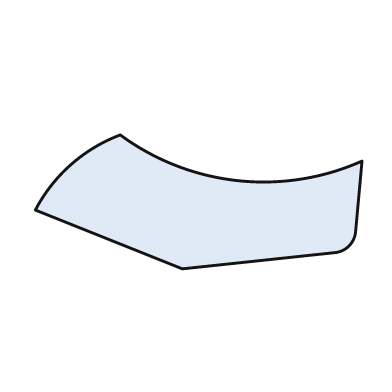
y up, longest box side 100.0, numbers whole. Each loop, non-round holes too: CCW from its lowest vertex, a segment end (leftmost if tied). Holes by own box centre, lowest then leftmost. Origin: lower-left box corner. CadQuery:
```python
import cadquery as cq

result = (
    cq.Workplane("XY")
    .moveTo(45.0, 0.0)
    .lineTo(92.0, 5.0)
    .threePointArc((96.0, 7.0), (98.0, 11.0))
    .lineTo(100.0, 33.0)
    .threePointArc((62.0, 27.0), (26.0, 41.0))
    .threePointArc((11.0, 32.0), (0.0, 18.0))
    .close()
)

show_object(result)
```